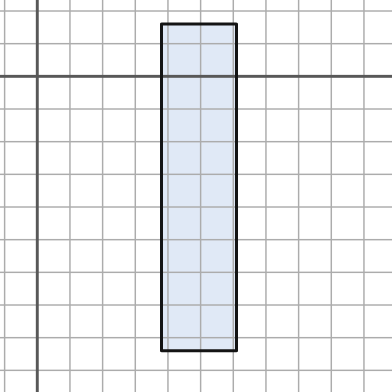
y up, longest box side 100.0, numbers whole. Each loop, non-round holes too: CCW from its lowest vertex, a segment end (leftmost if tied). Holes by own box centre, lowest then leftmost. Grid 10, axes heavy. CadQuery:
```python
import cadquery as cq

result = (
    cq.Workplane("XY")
    .moveTo(38.0, -84.0)
    .lineTo(61.0, -84.0)
    .lineTo(61.0, 16.0)
    .lineTo(38.0, 16.0)
    .close()
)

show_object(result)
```